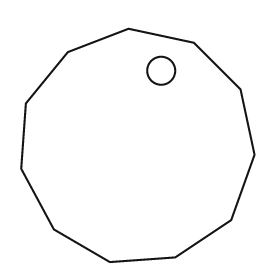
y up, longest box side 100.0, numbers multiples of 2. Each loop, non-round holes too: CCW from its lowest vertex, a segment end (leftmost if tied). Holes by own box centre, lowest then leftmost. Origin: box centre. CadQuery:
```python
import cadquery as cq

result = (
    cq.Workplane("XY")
    .moveTo(-12.0, -50.0)
    .lineTo(16.0, -48.0)
    .lineTo(40.0, -32.0)
    .lineTo(50.0, -4.0)
    .lineTo(44.0, 24.0)
    .lineTo(24.0, 44.0)
    .lineTo(-4.0, 50.0)
    .lineTo(-30.0, 40.0)
    .lineTo(-48.0, 18.0)
    .lineTo(-50.0, -10.0)
    .lineTo(-36.0, -36.0)
    .close()
    .moveTo(10.0, 32.0)
    .circle(6.0)
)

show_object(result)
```